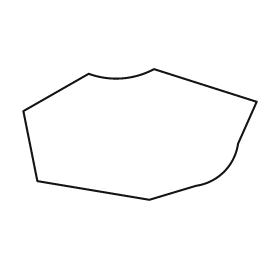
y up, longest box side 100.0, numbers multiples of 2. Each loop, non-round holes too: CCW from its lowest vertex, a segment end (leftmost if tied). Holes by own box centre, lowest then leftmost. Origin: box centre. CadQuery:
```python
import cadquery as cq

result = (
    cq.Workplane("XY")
    .moveTo(4.0, -28.0)
    .lineTo(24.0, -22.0)
    .threePointArc((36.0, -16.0), (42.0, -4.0))
    .lineTo(50.0, 14.0)
    .lineTo(6.0, 28.0)
    .threePointArc((-8.0, 24.0), (-22.0, 26.0))
    .lineTo(-50.0, 10.0)
    .lineTo(-44.0, -20.0)
    .close()
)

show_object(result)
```